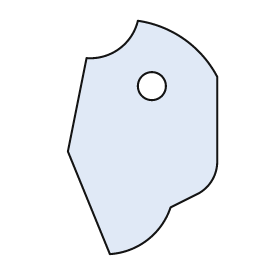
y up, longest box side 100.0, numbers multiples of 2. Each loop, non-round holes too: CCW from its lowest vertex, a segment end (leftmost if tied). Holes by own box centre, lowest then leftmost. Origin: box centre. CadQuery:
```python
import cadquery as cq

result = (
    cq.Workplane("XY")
    .moveTo(-14.0, -50.0)
    .threePointArc((2.0, -44.0), (12.0, -30.0))
    .lineTo(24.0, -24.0)
    .threePointArc((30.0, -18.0), (32.0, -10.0))
    .lineTo(32.0, 26.0)
    .threePointArc((18.0, 42.0), (-2.0, 50.0))
    .threePointArc((-10.0, 38.0), (-24.0, 34.0))
    .lineTo(-32.0, -6.0)
    .close()
    .moveTo(4.0, 22.0)
    .circle(6.0)
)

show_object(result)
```